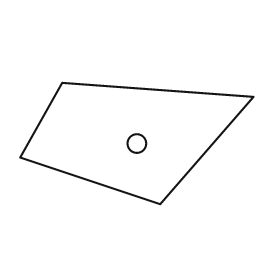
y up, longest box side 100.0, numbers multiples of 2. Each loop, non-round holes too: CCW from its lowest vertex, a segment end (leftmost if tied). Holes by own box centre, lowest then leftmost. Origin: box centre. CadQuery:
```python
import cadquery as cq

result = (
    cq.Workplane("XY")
    .moveTo(10.0, -26.0)
    .lineTo(50.0, 20.0)
    .lineTo(-32.0, 26.0)
    .lineTo(-50.0, -6.0)
    .close()
    .moveTo(0.0, 0.0)
    .circle(4.0)
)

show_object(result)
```